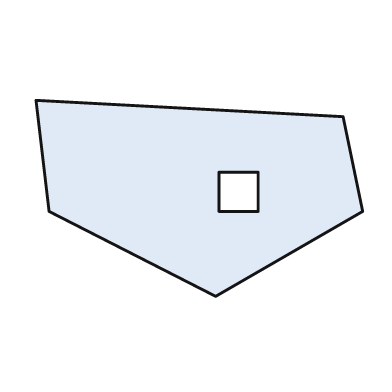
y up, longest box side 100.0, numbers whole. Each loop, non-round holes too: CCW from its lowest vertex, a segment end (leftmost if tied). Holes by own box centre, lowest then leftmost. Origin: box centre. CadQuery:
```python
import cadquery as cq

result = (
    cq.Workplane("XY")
    .moveTo(5.0, -30.0)
    .lineTo(50.0, -4.0)
    .lineTo(44.0, 25.0)
    .lineTo(-50.0, 30.0)
    .lineTo(-46.0, -4.0)
    .close()
    .moveTo(6.0, -4.0)
    .lineTo(18.0, -4.0)
    .lineTo(18.0, 8.0)
    .lineTo(6.0, 8.0)
    .close()
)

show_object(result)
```